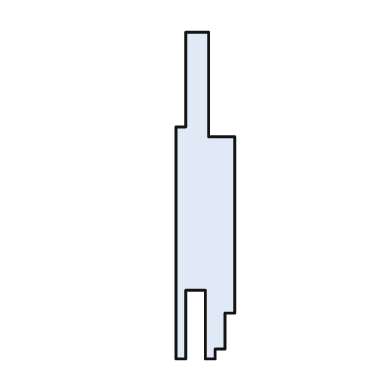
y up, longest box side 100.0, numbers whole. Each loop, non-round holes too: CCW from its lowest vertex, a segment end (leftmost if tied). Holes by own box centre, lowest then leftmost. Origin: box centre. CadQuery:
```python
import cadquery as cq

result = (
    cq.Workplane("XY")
    .moveTo(-9.0, -50.0)
    .lineTo(-6.0, -50.0)
    .lineTo(-6.0, -29.0)
    .lineTo(0.0, -29.0)
    .lineTo(0.0, -50.0)
    .lineTo(3.0, -50.0)
    .lineTo(3.0, -47.0)
    .lineTo(6.0, -47.0)
    .lineTo(6.0, -36.0)
    .lineTo(9.0, -36.0)
    .lineTo(9.0, 18.0)
    .lineTo(1.0, 18.0)
    .lineTo(1.0, 50.0)
    .lineTo(-6.0, 50.0)
    .lineTo(-6.0, 21.0)
    .lineTo(-9.0, 21.0)
    .close()
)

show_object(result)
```